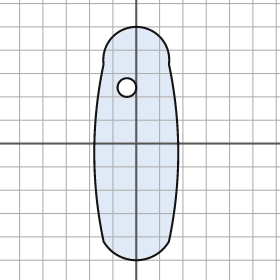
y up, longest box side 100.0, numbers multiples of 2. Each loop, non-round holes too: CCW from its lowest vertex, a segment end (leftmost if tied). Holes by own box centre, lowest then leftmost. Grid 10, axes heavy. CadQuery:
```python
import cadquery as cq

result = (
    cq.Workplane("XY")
    .moveTo(-14.0, -42.0)
    .threePointArc((0.0, -50.0), (14.0, -42.0))
    .threePointArc((18.0, -4.0), (14.0, 34.0))
    .threePointArc((0.0, 50.0), (-14.0, 34.0))
    .threePointArc((-18.0, -4.0), (-14.0, -42.0))
    .close()
    .moveTo(-4.0, 24.0)
    .circle(4.0)
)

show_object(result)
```